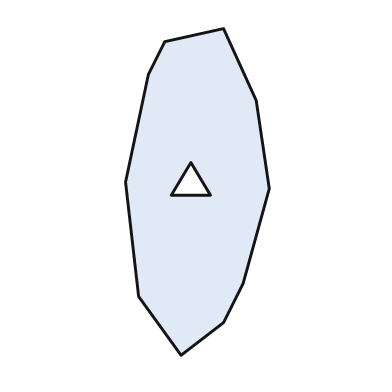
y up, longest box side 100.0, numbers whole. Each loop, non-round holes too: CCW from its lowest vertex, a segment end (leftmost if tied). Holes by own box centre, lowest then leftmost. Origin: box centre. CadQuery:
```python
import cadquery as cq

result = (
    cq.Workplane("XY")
    .moveTo(-5.0, -50.0)
    .lineTo(8.0, -40.0)
    .lineTo(14.0, -28.0)
    .lineTo(22.0, 1.0)
    .lineTo(18.0, 28.0)
    .lineTo(8.0, 50.0)
    .lineTo(-10.0, 46.0)
    .lineTo(-15.0, 36.0)
    .lineTo(-22.0, 3.0)
    .lineTo(-18.0, -32.0)
    .close()
    .moveTo(-8.0, -1.0)
    .lineTo(4.0, -1.0)
    .lineTo(-2.0, 9.0)
    .close()
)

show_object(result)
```